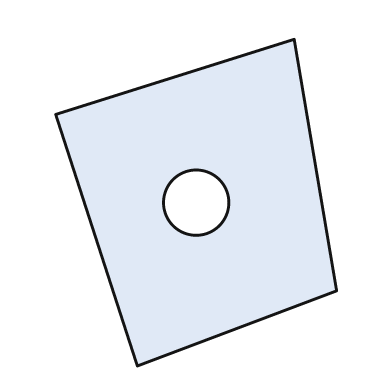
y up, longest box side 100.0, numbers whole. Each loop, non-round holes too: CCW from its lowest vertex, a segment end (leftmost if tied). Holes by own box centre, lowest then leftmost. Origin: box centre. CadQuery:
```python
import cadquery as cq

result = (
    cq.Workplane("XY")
    .moveTo(-18.0, -50.0)
    .lineTo(43.0, -27.0)
    .lineTo(30.0, 50.0)
    .lineTo(-43.0, 27.0)
    .close()
    .moveTo(0.0, 0.0)
    .circle(10.0)
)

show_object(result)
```